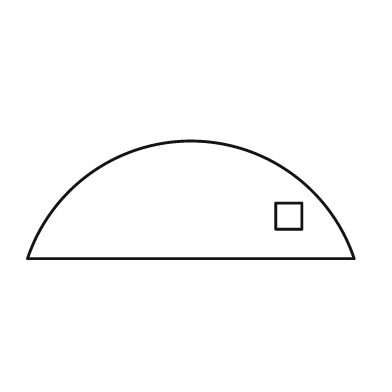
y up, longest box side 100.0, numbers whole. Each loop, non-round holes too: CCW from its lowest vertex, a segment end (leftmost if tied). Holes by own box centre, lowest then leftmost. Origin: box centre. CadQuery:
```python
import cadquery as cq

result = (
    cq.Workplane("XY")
    .moveTo(-50.0, -18.0)
    .lineTo(50.0, -18.0)
    .threePointArc((0.0, 18.0), (-50.0, -18.0))
    .close()
    .moveTo(26.0, -9.0)
    .lineTo(34.0, -9.0)
    .lineTo(34.0, -1.0)
    .lineTo(26.0, -1.0)
    .close()
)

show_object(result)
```